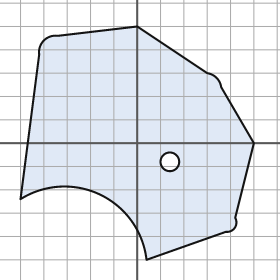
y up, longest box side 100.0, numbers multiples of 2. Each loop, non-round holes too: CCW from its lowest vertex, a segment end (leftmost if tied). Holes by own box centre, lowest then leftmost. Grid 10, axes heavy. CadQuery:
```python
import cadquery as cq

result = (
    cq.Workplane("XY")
    .moveTo(4.0, -50.0)
    .lineTo(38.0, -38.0)
    .threePointArc((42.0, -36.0), (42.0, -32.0))
    .lineTo(50.0, 0.0)
    .lineTo(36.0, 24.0)
    .threePointArc((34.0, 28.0), (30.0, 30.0))
    .lineTo(0.0, 50.0)
    .lineTo(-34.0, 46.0)
    .threePointArc((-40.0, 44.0), (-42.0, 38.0))
    .lineTo(-50.0, -24.0)
    .threePointArc((-16.0, -22.0), (4.0, -50.0))
    .close()
    .moveTo(14.0, -8.0)
    .circle(4.0)
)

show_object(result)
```